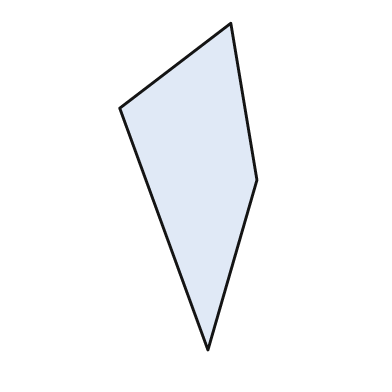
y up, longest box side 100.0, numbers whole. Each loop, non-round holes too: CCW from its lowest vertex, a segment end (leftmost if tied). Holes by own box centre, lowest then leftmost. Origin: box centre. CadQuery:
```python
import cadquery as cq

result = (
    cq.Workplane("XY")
    .moveTo(6.0, -50.0)
    .lineTo(21.0, 2.0)
    .lineTo(13.0, 50.0)
    .lineTo(-21.0, 24.0)
    .close()
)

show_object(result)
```